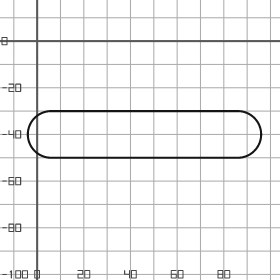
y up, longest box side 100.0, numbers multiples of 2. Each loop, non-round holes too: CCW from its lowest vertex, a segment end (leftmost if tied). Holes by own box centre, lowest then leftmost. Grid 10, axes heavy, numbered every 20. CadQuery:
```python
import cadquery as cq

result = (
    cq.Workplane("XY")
    .moveTo(6.0, -50.0)
    .lineTo(86.0, -50.0)
    .threePointArc((96.0, -40.0), (86.0, -30.0))
    .lineTo(6.0, -30.0)
    .threePointArc((-4.0, -40.0), (6.0, -50.0))
    .close()
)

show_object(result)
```